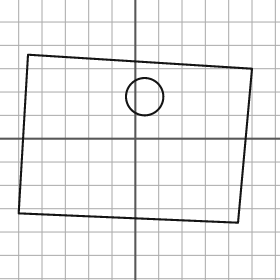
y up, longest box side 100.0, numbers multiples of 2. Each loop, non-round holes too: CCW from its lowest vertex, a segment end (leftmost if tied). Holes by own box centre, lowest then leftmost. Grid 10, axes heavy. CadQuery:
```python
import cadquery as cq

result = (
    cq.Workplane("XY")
    .moveTo(44.0, -36.0)
    .lineTo(50.0, 30.0)
    .lineTo(-46.0, 36.0)
    .lineTo(-50.0, -32.0)
    .close()
    .moveTo(4.0, 18.0)
    .circle(8.0)
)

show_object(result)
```